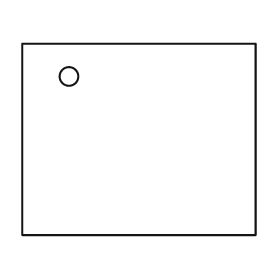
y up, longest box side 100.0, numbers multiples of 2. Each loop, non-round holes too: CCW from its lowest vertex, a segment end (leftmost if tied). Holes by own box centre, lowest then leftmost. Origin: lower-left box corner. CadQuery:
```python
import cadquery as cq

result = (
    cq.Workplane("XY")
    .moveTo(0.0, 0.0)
    .lineTo(100.0, 0.0)
    .lineTo(100.0, 82.0)
    .lineTo(0.0, 82.0)
    .close()
    .moveTo(20.0, 68.0)
    .circle(4.0)
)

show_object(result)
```